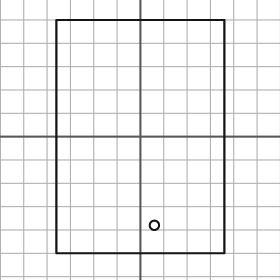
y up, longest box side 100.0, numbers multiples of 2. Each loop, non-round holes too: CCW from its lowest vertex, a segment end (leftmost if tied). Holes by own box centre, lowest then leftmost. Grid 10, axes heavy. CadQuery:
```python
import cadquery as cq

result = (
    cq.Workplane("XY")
    .moveTo(-36.0, -50.0)
    .lineTo(36.0, -50.0)
    .lineTo(36.0, 50.0)
    .lineTo(-36.0, 50.0)
    .close()
    .moveTo(6.0, -38.0)
    .circle(2.0)
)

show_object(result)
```